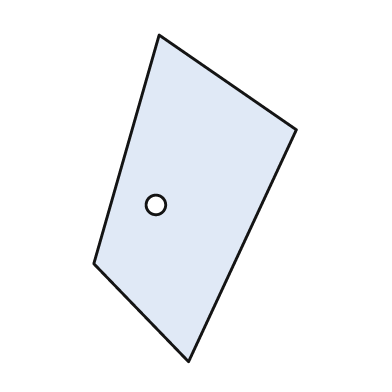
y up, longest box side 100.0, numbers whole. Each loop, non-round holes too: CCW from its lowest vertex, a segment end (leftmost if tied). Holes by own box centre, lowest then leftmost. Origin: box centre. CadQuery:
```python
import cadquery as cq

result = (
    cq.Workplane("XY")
    .moveTo(-2.0, -50.0)
    .lineTo(31.0, 21.0)
    .lineTo(-11.0, 50.0)
    .lineTo(-31.0, -20.0)
    .close()
    .moveTo(-12.0, -2.0)
    .circle(3.0)
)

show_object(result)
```